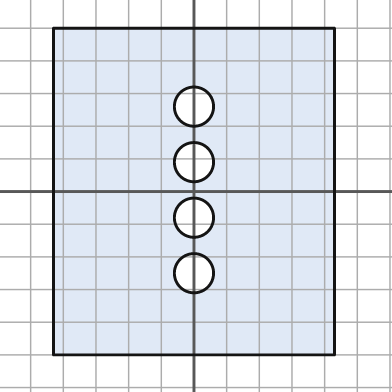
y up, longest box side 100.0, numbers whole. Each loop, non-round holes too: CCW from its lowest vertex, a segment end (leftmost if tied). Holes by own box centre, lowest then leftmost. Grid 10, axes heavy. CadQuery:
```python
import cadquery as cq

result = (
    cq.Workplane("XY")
    .moveTo(-43.0, -50.0)
    .lineTo(43.0, -50.0)
    .lineTo(43.0, 50.0)
    .lineTo(-43.0, 50.0)
    .close()
    .moveTo(0.0, -25.0)
    .circle(6.0)
    .moveTo(0.0, -8.0)
    .circle(6.0)
    .moveTo(0.0, 9.0)
    .circle(6.0)
    .moveTo(0.0, 26.0)
    .circle(6.0)
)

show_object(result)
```